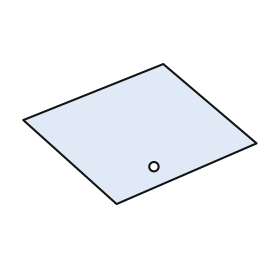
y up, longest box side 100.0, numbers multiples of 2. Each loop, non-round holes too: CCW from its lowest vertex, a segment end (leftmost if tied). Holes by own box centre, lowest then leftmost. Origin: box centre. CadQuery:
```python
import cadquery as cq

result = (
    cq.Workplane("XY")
    .moveTo(-10.0, -30.0)
    .lineTo(50.0, -4.0)
    .lineTo(10.0, 30.0)
    .lineTo(-50.0, 6.0)
    .close()
    .moveTo(6.0, -14.0)
    .circle(2.0)
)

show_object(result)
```